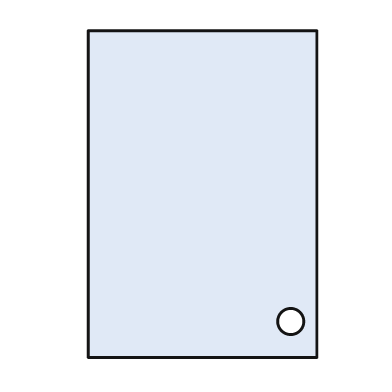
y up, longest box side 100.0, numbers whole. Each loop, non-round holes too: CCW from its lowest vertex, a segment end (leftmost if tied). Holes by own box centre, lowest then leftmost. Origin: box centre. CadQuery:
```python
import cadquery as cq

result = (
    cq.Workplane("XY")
    .moveTo(-35.0, -50.0)
    .lineTo(35.0, -50.0)
    .lineTo(35.0, 50.0)
    .lineTo(-35.0, 50.0)
    .close()
    .moveTo(27.0, -39.0)
    .circle(4.0)
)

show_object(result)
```